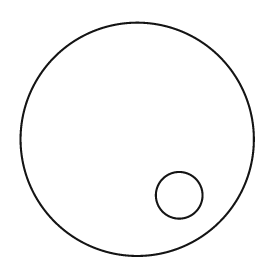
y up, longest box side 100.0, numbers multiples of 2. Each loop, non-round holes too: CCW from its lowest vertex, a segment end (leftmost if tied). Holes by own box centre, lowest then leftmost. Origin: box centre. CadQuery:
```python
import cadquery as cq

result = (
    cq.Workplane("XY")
    .moveTo(0.0, 0.0)
    .circle(50.0)
    .moveTo(18.0, -24.0)
    .circle(10.0)
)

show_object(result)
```